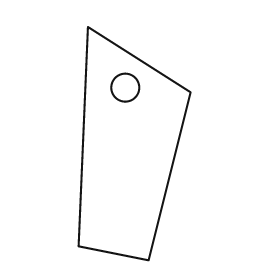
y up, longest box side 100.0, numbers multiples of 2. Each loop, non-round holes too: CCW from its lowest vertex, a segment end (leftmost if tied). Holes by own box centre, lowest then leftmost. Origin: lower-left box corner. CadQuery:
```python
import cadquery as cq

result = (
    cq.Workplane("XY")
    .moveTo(30.0, 0.0)
    .lineTo(48.0, 72.0)
    .lineTo(4.0, 100.0)
    .lineTo(0.0, 6.0)
    .close()
    .moveTo(20.0, 74.0)
    .circle(6.0)
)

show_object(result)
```